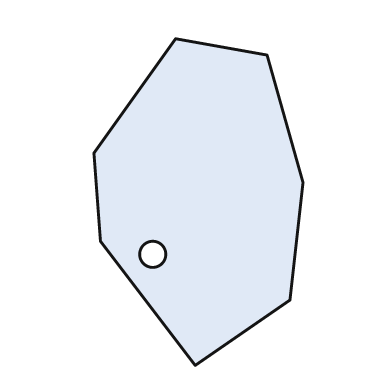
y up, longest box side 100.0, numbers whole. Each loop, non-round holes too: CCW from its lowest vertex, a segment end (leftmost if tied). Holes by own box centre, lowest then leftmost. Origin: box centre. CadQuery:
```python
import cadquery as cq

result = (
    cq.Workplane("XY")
    .moveTo(-1.0, -50.0)
    .lineTo(28.0, -30.0)
    .lineTo(32.0, 6.0)
    .lineTo(21.0, 45.0)
    .lineTo(-7.0, 50.0)
    .lineTo(-32.0, 15.0)
    .lineTo(-30.0, -12.0)
    .close()
    .moveTo(-14.0, -16.0)
    .circle(4.0)
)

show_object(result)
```